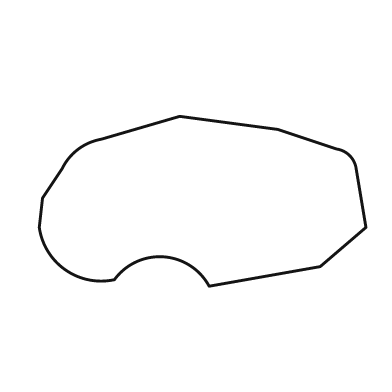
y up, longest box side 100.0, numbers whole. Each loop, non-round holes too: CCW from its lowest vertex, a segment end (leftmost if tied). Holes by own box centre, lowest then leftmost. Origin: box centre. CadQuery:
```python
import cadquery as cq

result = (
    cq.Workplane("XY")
    .moveTo(2.0, -26.0)
    .lineTo(36.0, -20.0)
    .lineTo(50.0, -8.0)
    .lineTo(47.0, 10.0)
    .threePointArc((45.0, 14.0), (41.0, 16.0))
    .lineTo(23.0, 22.0)
    .lineTo(-7.0, 26.0)
    .lineTo(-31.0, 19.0)
    .threePointArc((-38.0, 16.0), (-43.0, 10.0))
    .lineTo(-49.0, 1.0)
    .lineTo(-50.0, -8.0)
    .threePointArc((-42.0, -21.0), (-27.0, -24.0))
    .threePointArc((-12.0, -17.0), (2.0, -26.0))
    .close()
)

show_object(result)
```